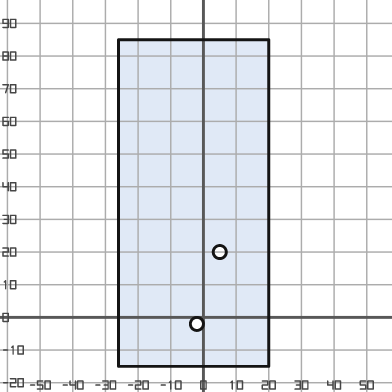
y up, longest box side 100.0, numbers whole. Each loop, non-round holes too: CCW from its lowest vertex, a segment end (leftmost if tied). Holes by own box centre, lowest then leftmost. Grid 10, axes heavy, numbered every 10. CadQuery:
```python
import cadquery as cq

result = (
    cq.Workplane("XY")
    .moveTo(-26.0, -15.0)
    .lineTo(20.0, -15.0)
    .lineTo(20.0, 85.0)
    .lineTo(-26.0, 85.0)
    .close()
    .moveTo(-2.0, -2.0)
    .circle(2.0)
    .moveTo(5.0, 20.0)
    .circle(2.0)
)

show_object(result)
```